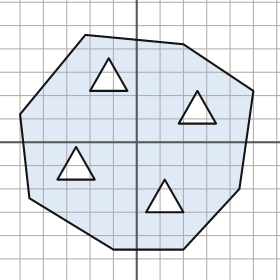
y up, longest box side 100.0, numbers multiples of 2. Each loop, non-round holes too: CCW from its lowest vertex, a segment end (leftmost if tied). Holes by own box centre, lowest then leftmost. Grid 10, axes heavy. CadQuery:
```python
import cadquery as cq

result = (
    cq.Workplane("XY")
    .moveTo(-10.0, -46.0)
    .lineTo(20.0, -46.0)
    .lineTo(44.0, -20.0)
    .lineTo(50.0, 22.0)
    .lineTo(20.0, 42.0)
    .lineTo(-22.0, 46.0)
    .lineTo(-50.0, 12.0)
    .lineTo(-46.0, -24.0)
    .close()
    .moveTo(4.0, -30.0)
    .lineTo(20.0, -30.0)
    .lineTo(12.0, -16.0)
    .close()
    .moveTo(-34.0, -16.0)
    .lineTo(-18.0, -16.0)
    .lineTo(-26.0, -2.0)
    .close()
    .moveTo(18.0, 8.0)
    .lineTo(34.0, 8.0)
    .lineTo(26.0, 22.0)
    .close()
    .moveTo(-20.0, 22.0)
    .lineTo(-4.0, 22.0)
    .lineTo(-12.0, 36.0)
    .close()
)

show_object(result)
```